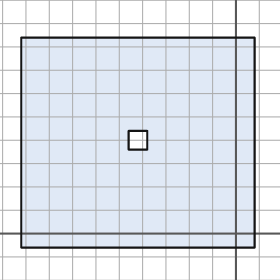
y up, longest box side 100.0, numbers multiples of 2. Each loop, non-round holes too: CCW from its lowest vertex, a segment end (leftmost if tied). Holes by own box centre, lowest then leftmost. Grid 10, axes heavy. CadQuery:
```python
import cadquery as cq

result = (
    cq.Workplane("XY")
    .moveTo(-92.0, -6.0)
    .lineTo(8.0, -6.0)
    .lineTo(8.0, 84.0)
    .lineTo(-92.0, 84.0)
    .close()
    .moveTo(-46.0, 36.0)
    .lineTo(-38.0, 36.0)
    .lineTo(-38.0, 44.0)
    .lineTo(-46.0, 44.0)
    .close()
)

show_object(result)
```